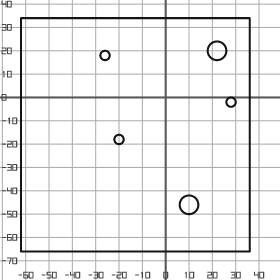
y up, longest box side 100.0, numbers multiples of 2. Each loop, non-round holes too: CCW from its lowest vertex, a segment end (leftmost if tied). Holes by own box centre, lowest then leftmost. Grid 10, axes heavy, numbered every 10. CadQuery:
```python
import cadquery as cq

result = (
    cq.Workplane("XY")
    .moveTo(-62.0, -66.0)
    .lineTo(36.0, -66.0)
    .lineTo(36.0, 34.0)
    .lineTo(-62.0, 34.0)
    .close()
    .moveTo(10.0, -46.0)
    .circle(4.0)
    .moveTo(-20.0, -18.0)
    .circle(2.0)
    .moveTo(28.0, -2.0)
    .circle(2.0)
    .moveTo(-26.0, 18.0)
    .circle(2.0)
    .moveTo(22.0, 20.0)
    .circle(4.0)
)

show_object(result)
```